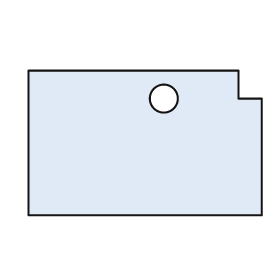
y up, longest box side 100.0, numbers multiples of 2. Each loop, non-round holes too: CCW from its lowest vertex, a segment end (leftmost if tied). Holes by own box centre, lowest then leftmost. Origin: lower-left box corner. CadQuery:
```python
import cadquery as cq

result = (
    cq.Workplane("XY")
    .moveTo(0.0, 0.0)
    .lineTo(100.0, 0.0)
    .lineTo(100.0, 50.0)
    .lineTo(90.0, 50.0)
    .lineTo(90.0, 62.0)
    .lineTo(0.0, 62.0)
    .close()
    .moveTo(58.0, 50.0)
    .circle(6.0)
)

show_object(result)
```